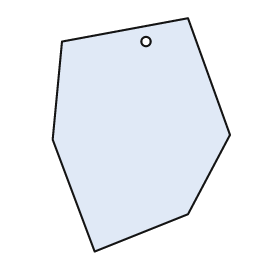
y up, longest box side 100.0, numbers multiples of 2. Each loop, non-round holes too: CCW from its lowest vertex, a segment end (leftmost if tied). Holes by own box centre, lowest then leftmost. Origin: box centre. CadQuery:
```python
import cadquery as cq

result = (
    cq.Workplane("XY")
    .moveTo(-20.0, -50.0)
    .lineTo(20.0, -34.0)
    .lineTo(38.0, 0.0)
    .lineTo(20.0, 50.0)
    .lineTo(-34.0, 40.0)
    .lineTo(-38.0, -2.0)
    .close()
    .moveTo(2.0, 40.0)
    .circle(2.0)
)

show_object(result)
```